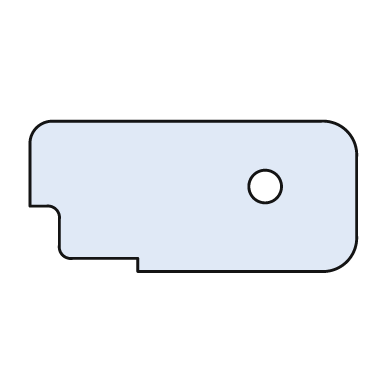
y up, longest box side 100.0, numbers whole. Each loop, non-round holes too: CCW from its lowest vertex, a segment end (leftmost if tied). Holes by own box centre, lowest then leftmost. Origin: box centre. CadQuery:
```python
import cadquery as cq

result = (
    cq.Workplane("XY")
    .moveTo(-17.0, -23.0)
    .lineTo(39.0, -23.0)
    .threePointArc((47.0, -20.0), (50.0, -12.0))
    .lineTo(50.0, 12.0)
    .threePointArc((47.0, 20.0), (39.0, 23.0))
    .lineTo(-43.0, 23.0)
    .threePointArc((-48.0, 21.0), (-50.0, 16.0))
    .lineTo(-50.0, -3.0)
    .lineTo(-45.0, -3.0)
    .threePointArc((-42.0, -4.0), (-41.0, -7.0))
    .lineTo(-41.0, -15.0)
    .threePointArc((-40.0, -18.0), (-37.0, -19.0))
    .lineTo(-17.0, -19.0)
    .close()
    .moveTo(22.0, 3.0)
    .circle(5.0)
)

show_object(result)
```